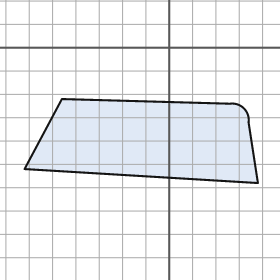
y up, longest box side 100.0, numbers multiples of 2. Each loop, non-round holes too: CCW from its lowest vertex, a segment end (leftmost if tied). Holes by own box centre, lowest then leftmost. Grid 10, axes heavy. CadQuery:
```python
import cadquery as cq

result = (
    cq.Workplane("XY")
    .moveTo(38.0, -58.0)
    .lineTo(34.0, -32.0)
    .threePointArc((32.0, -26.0), (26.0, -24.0))
    .lineTo(-46.0, -22.0)
    .lineTo(-62.0, -52.0)
    .close()
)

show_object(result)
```